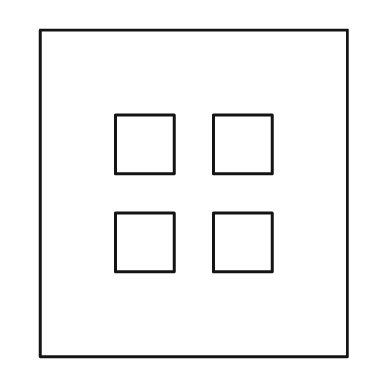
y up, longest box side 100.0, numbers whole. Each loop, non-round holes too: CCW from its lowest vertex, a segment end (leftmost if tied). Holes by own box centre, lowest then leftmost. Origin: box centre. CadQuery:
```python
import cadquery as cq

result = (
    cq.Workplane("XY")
    .moveTo(-47.0, -50.0)
    .lineTo(47.0, -50.0)
    .lineTo(47.0, 50.0)
    .lineTo(-47.0, 50.0)
    .close()
    .moveTo(-24.0, -24.0)
    .lineTo(-6.0, -24.0)
    .lineTo(-6.0, -6.0)
    .lineTo(-24.0, -6.0)
    .close()
    .moveTo(6.0, -24.0)
    .lineTo(24.0, -24.0)
    .lineTo(24.0, -6.0)
    .lineTo(6.0, -6.0)
    .close()
    .moveTo(-24.0, 6.0)
    .lineTo(-6.0, 6.0)
    .lineTo(-6.0, 24.0)
    .lineTo(-24.0, 24.0)
    .close()
    .moveTo(6.0, 6.0)
    .lineTo(24.0, 6.0)
    .lineTo(24.0, 24.0)
    .lineTo(6.0, 24.0)
    .close()
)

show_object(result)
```